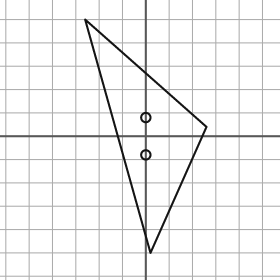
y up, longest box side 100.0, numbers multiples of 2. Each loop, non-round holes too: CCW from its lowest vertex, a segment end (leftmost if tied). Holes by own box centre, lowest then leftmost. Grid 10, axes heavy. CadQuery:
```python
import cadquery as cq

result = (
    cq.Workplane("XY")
    .moveTo(2.0, -50.0)
    .lineTo(26.0, 4.0)
    .lineTo(-26.0, 50.0)
    .close()
    .moveTo(0.0, -8.0)
    .circle(2.0)
    .moveTo(0.0, 8.0)
    .circle(2.0)
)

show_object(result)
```